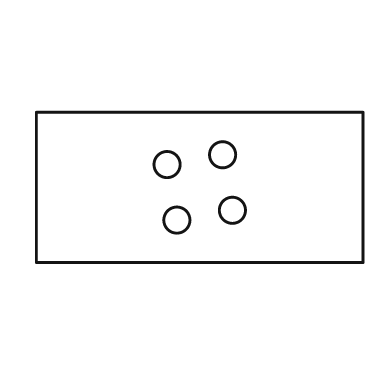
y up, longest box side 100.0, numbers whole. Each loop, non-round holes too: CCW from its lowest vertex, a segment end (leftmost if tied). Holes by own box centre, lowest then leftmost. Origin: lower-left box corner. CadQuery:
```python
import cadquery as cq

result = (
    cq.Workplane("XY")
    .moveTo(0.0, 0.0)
    .lineTo(100.0, 0.0)
    .lineTo(100.0, 46.0)
    .lineTo(0.0, 46.0)
    .close()
    .moveTo(43.0, 13.0)
    .circle(4.0)
    .moveTo(60.0, 16.0)
    .circle(4.0)
    .moveTo(40.0, 30.0)
    .circle(4.0)
    .moveTo(57.0, 33.0)
    .circle(4.0)
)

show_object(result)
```